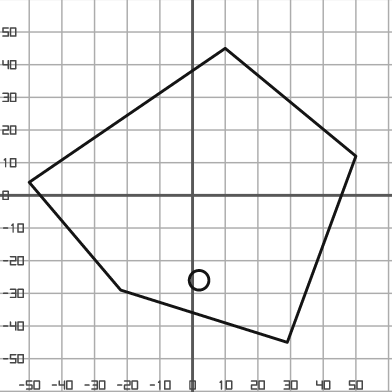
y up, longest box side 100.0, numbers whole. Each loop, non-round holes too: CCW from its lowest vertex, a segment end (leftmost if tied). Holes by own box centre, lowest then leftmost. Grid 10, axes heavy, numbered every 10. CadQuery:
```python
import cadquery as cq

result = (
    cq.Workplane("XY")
    .moveTo(29.0, -45.0)
    .lineTo(50.0, 12.0)
    .lineTo(10.0, 45.0)
    .lineTo(-50.0, 4.0)
    .lineTo(-22.0, -29.0)
    .close()
    .moveTo(2.0, -26.0)
    .circle(3.0)
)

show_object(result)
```